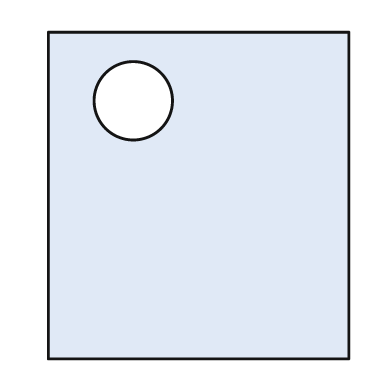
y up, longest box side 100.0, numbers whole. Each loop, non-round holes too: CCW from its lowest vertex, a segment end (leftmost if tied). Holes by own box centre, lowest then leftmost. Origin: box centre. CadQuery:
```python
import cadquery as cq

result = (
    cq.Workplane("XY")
    .moveTo(-46.0, -50.0)
    .lineTo(46.0, -50.0)
    .lineTo(46.0, 50.0)
    .lineTo(-46.0, 50.0)
    .close()
    .moveTo(-20.0, 29.0)
    .circle(12.0)
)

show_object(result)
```